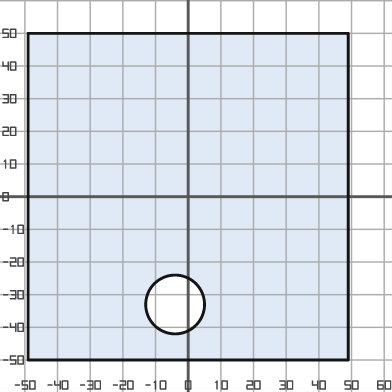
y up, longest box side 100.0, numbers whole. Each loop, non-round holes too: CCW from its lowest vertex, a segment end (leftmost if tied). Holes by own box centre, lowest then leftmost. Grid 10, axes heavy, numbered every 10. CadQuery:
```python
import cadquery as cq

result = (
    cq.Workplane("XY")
    .moveTo(-49.0, -50.0)
    .lineTo(49.0, -50.0)
    .lineTo(49.0, 50.0)
    .lineTo(-49.0, 50.0)
    .close()
    .moveTo(-4.0, -33.0)
    .circle(9.0)
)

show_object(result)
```